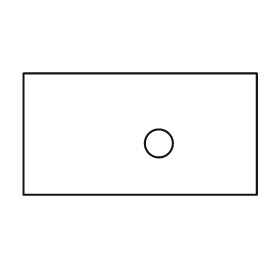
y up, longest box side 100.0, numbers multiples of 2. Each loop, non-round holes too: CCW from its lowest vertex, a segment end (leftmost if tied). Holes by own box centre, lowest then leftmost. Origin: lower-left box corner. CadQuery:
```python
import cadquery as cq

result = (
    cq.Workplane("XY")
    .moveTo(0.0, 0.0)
    .lineTo(100.0, 0.0)
    .lineTo(100.0, 52.0)
    .lineTo(0.0, 52.0)
    .close()
    .moveTo(58.0, 22.0)
    .circle(6.0)
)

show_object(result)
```